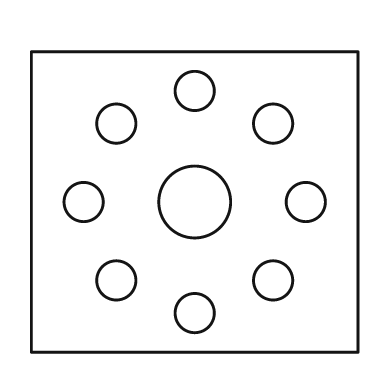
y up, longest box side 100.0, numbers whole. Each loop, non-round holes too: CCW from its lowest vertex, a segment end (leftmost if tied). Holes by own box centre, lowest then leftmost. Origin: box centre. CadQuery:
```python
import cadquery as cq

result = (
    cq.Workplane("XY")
    .moveTo(-50.0, -46.0)
    .lineTo(50.0, -46.0)
    .lineTo(50.0, 46.0)
    .lineTo(-50.0, 46.0)
    .close()
    .moveTo(0.0, -34.0)
    .circle(6.0)
    .moveTo(-24.0, -24.0)
    .circle(6.0)
    .moveTo(24.0, -24.0)
    .circle(6.0)
    .moveTo(-34.0, 0.0)
    .circle(6.0)
    .moveTo(0.0, 0.0)
    .circle(11.0)
    .moveTo(34.0, 0.0)
    .circle(6.0)
    .moveTo(-24.0, 24.0)
    .circle(6.0)
    .moveTo(24.0, 24.0)
    .circle(6.0)
    .moveTo(0.0, 34.0)
    .circle(6.0)
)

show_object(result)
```